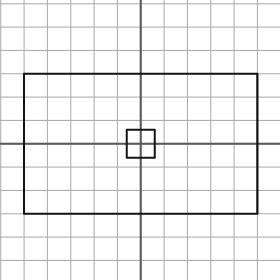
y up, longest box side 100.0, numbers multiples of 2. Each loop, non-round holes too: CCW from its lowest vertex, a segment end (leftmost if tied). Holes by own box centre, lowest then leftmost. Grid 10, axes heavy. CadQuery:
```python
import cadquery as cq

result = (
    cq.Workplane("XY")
    .moveTo(-50.0, -30.0)
    .lineTo(50.0, -30.0)
    .lineTo(50.0, 30.0)
    .lineTo(-50.0, 30.0)
    .close()
    .moveTo(-6.0, -6.0)
    .lineTo(6.0, -6.0)
    .lineTo(6.0, 6.0)
    .lineTo(-6.0, 6.0)
    .close()
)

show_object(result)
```